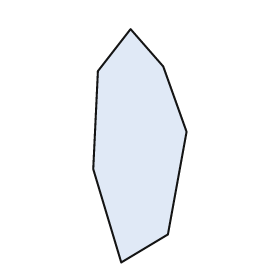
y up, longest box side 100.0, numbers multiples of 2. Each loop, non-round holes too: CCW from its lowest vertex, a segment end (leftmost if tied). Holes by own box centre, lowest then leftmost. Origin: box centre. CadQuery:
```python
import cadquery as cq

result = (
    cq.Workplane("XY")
    .moveTo(-8.0, -50.0)
    .lineTo(12.0, -38.0)
    .lineTo(20.0, 6.0)
    .lineTo(10.0, 34.0)
    .lineTo(-4.0, 50.0)
    .lineTo(-18.0, 32.0)
    .lineTo(-20.0, -10.0)
    .close()
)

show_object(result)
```